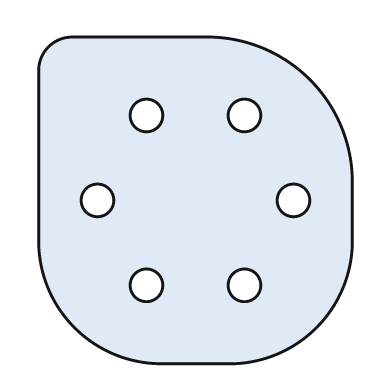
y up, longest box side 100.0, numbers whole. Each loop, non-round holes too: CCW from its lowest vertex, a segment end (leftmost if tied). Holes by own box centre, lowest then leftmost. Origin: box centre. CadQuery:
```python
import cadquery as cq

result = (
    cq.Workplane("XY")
    .moveTo(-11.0, -50.0)
    .lineTo(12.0, -50.0)
    .threePointArc((37.0, -39.0), (48.0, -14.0))
    .lineTo(48.0, 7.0)
    .threePointArc((35.0, 37.0), (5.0, 50.0))
    .lineTo(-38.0, 50.0)
    .threePointArc((-45.0, 47.0), (-48.0, 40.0))
    .lineTo(-48.0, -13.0)
    .threePointArc((-37.0, -39.0), (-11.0, -50.0))
    .close()
    .moveTo(-15.0, -26.0)
    .circle(5.0)
    .moveTo(15.0, -26.0)
    .circle(5.0)
    .moveTo(-30.0, 0.0)
    .circle(5.0)
    .moveTo(30.0, 0.0)
    .circle(5.0)
    .moveTo(-15.0, 26.0)
    .circle(5.0)
    .moveTo(15.0, 26.0)
    .circle(5.0)
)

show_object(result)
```